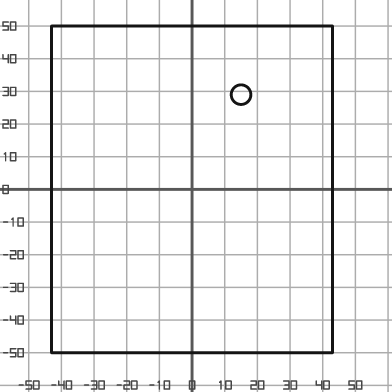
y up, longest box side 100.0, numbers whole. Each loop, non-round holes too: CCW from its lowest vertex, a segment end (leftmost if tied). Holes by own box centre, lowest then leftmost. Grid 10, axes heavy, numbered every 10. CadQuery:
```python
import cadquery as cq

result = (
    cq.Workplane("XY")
    .moveTo(-43.0, -50.0)
    .lineTo(43.0, -50.0)
    .lineTo(43.0, 50.0)
    .lineTo(-43.0, 50.0)
    .close()
    .moveTo(15.0, 29.0)
    .circle(3.0)
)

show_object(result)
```